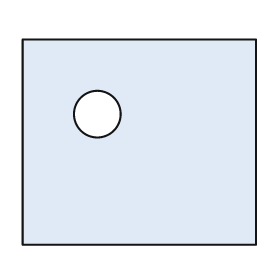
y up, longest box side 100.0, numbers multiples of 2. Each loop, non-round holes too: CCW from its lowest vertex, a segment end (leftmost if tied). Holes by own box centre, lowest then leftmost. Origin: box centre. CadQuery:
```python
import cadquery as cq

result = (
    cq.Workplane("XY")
    .moveTo(-50.0, -44.0)
    .lineTo(50.0, -44.0)
    .lineTo(50.0, 44.0)
    .lineTo(-50.0, 44.0)
    .close()
    .moveTo(-18.0, 12.0)
    .circle(10.0)
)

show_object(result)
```